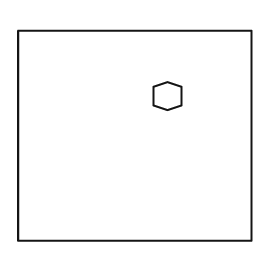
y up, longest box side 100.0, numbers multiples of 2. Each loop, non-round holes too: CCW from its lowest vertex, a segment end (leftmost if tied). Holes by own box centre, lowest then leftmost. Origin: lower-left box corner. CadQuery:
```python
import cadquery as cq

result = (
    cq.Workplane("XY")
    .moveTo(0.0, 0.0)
    .lineTo(100.0, 0.0)
    .lineTo(100.0, 90.0)
    .lineTo(0.0, 90.0)
    .close()
    .moveTo(64.0, 56.0)
    .lineTo(70.0, 58.0)
    .lineTo(70.0, 66.0)
    .lineTo(64.0, 68.0)
    .lineTo(58.0, 66.0)
    .lineTo(58.0, 58.0)
    .close()
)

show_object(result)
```